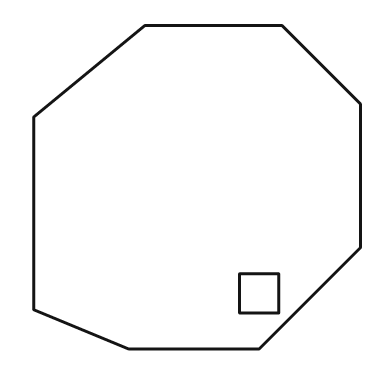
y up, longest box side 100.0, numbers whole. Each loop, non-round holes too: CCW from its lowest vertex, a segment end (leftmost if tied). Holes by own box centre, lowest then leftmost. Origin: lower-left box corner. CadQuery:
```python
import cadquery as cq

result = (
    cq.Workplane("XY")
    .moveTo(29.0, 0.0)
    .lineTo(69.0, 0.0)
    .lineTo(100.0, 31.0)
    .lineTo(100.0, 75.0)
    .lineTo(76.0, 99.0)
    .lineTo(34.0, 99.0)
    .lineTo(0.0, 71.0)
    .lineTo(0.0, 12.0)
    .close()
    .moveTo(63.0, 11.0)
    .lineTo(75.0, 11.0)
    .lineTo(75.0, 23.0)
    .lineTo(63.0, 23.0)
    .close()
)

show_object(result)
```